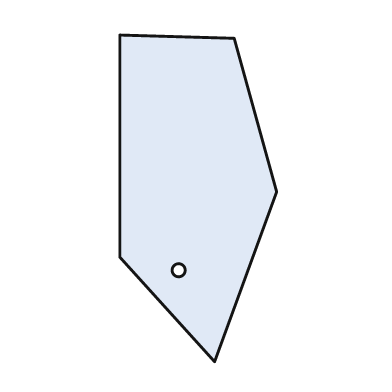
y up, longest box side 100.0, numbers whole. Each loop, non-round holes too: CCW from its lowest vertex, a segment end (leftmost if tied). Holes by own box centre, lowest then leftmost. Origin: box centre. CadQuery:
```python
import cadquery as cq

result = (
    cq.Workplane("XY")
    .moveTo(5.0, -50.0)
    .lineTo(24.0, 2.0)
    .lineTo(11.0, 49.0)
    .lineTo(-24.0, 50.0)
    .lineTo(-24.0, -18.0)
    .close()
    .moveTo(-6.0, -22.0)
    .circle(2.0)
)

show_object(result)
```